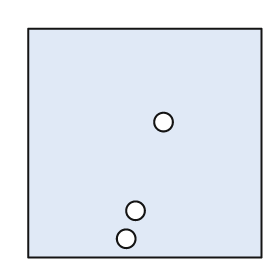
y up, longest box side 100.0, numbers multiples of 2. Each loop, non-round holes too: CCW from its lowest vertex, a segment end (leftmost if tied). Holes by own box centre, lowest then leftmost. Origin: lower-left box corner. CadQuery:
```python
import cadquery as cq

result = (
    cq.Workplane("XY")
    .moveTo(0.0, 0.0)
    .lineTo(100.0, 0.0)
    .lineTo(100.0, 98.0)
    .lineTo(0.0, 98.0)
    .close()
    .moveTo(42.0, 8.0)
    .circle(4.0)
    .moveTo(46.0, 20.0)
    .circle(4.0)
    .moveTo(58.0, 58.0)
    .circle(4.0)
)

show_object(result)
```